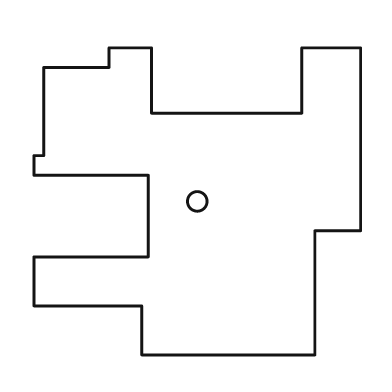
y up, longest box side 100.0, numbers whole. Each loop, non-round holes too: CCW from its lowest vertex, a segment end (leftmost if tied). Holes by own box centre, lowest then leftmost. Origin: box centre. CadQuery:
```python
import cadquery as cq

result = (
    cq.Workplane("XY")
    .moveTo(-17.0, -47.0)
    .lineTo(36.0, -47.0)
    .lineTo(36.0, -9.0)
    .lineTo(50.0, -9.0)
    .lineTo(50.0, 47.0)
    .lineTo(32.0, 47.0)
    .lineTo(32.0, 27.0)
    .lineTo(-14.0, 27.0)
    .lineTo(-14.0, 47.0)
    .lineTo(-27.0, 47.0)
    .lineTo(-27.0, 41.0)
    .lineTo(-47.0, 41.0)
    .lineTo(-47.0, 14.0)
    .lineTo(-50.0, 14.0)
    .lineTo(-50.0, 8.0)
    .lineTo(-15.0, 8.0)
    .lineTo(-15.0, -17.0)
    .lineTo(-50.0, -17.0)
    .lineTo(-50.0, -32.0)
    .lineTo(-17.0, -32.0)
    .close()
    .moveTo(0.0, 0.0)
    .circle(3.0)
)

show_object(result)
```